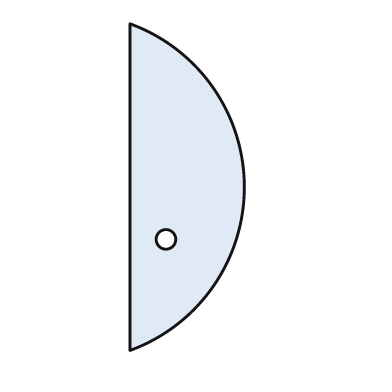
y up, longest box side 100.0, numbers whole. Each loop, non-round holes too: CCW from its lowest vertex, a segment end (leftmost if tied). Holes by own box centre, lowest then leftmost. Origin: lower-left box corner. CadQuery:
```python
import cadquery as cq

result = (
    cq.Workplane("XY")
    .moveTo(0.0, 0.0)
    .threePointArc((35.0, 50.0), (0.0, 100.0))
    .close()
    .moveTo(11.0, 34.0)
    .circle(3.0)
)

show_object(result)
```